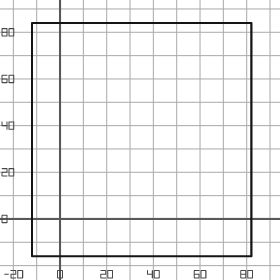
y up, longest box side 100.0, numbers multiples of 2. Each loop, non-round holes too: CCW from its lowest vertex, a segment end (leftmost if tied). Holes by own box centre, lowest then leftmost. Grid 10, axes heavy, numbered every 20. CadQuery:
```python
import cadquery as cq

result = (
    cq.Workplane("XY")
    .moveTo(-12.0, -16.0)
    .lineTo(82.0, -16.0)
    .lineTo(82.0, 84.0)
    .lineTo(-12.0, 84.0)
    .close()
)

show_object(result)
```